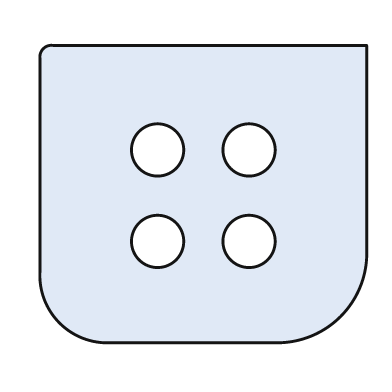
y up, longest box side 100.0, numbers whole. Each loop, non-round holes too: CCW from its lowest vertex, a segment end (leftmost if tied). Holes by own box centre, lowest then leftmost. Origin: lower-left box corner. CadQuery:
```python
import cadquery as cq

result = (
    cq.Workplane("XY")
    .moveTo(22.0, 0.0)
    .lineTo(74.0, 0.0)
    .threePointArc((92.0, 8.0), (100.0, 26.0))
    .lineTo(100.0, 91.0)
    .lineTo(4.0, 91.0)
    .threePointArc((1.0, 90.0), (0.0, 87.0))
    .lineTo(0.0, 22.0)
    .threePointArc((6.0, 6.0), (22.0, 0.0))
    .close()
    .moveTo(36.0, 31.0)
    .circle(8.0)
    .moveTo(64.0, 31.0)
    .circle(8.0)
    .moveTo(36.0, 59.0)
    .circle(8.0)
    .moveTo(64.0, 59.0)
    .circle(8.0)
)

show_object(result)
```